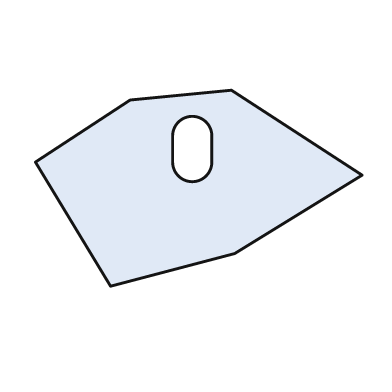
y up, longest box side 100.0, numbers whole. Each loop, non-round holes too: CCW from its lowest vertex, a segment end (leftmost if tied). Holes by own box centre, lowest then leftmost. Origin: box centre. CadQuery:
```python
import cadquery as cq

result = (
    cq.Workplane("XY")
    .moveTo(-27.0, -30.0)
    .lineTo(11.0, -20.0)
    .lineTo(50.0, 4.0)
    .lineTo(10.0, 30.0)
    .lineTo(-21.0, 27.0)
    .lineTo(-50.0, 8.0)
    .close()
    .moveTo(-8.0, 8.0)
    .threePointArc((-2.0, 2.0), (4.0, 8.0))
    .lineTo(4.0, 16.0)
    .threePointArc((-2.0, 22.0), (-8.0, 16.0))
    .close()
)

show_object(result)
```